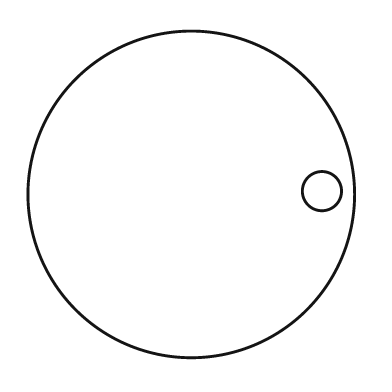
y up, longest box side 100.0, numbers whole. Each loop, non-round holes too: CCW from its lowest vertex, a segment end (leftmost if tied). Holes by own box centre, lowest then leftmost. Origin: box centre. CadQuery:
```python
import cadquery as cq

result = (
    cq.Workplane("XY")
    .moveTo(0.0, 0.0)
    .circle(50.0)
    .moveTo(40.0, 1.0)
    .circle(6.0)
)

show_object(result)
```